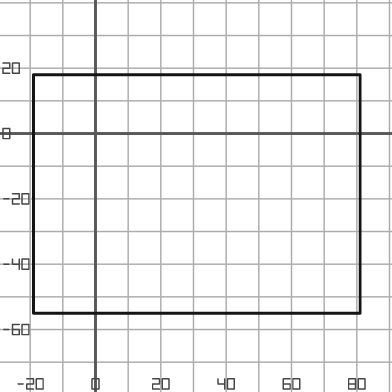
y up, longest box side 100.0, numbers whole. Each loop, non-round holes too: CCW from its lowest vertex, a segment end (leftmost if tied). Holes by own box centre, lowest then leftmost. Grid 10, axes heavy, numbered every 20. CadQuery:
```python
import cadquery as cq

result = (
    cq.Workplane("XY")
    .moveTo(-19.0, -55.0)
    .lineTo(81.0, -55.0)
    .lineTo(81.0, 18.0)
    .lineTo(-19.0, 18.0)
    .close()
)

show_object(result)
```